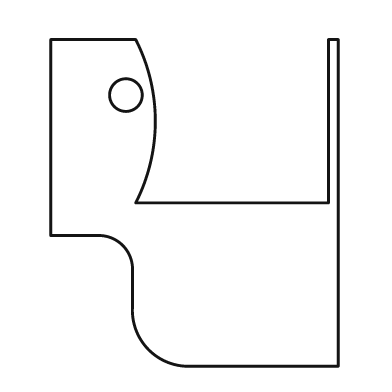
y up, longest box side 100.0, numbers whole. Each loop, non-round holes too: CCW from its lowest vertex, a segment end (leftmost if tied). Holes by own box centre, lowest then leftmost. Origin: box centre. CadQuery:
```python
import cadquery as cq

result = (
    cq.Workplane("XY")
    .moveTo(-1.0, -50.0)
    .lineTo(44.0, -50.0)
    .lineTo(44.0, 50.0)
    .lineTo(41.0, 50.0)
    .lineTo(41.0, 0.0)
    .lineTo(-18.0, 0.0)
    .threePointArc((-12.0, 25.0), (-18.0, 50.0))
    .lineTo(-44.0, 50.0)
    .lineTo(-44.0, -10.0)
    .lineTo(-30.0, -10.0)
    .threePointArc((-22.0, -13.0), (-19.0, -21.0))
    .lineTo(-19.0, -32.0)
    .threePointArc((-14.0, -45.0), (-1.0, -50.0))
    .close()
    .moveTo(-21.0, 33.0)
    .circle(5.0)
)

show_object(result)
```